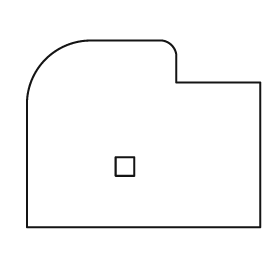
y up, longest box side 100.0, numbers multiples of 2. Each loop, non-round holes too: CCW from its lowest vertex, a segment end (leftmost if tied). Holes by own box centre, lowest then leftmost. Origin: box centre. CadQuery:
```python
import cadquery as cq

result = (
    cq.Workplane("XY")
    .moveTo(-50.0, -40.0)
    .lineTo(50.0, -40.0)
    .lineTo(50.0, 22.0)
    .lineTo(14.0, 22.0)
    .lineTo(14.0, 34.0)
    .threePointArc((12.0, 38.0), (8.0, 40.0))
    .lineTo(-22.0, 40.0)
    .threePointArc((-42.0, 32.0), (-50.0, 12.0))
    .close()
    .moveTo(-12.0, -18.0)
    .lineTo(-4.0, -18.0)
    .lineTo(-4.0, -10.0)
    .lineTo(-12.0, -10.0)
    .close()
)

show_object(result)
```